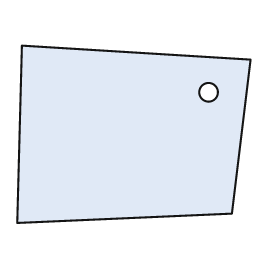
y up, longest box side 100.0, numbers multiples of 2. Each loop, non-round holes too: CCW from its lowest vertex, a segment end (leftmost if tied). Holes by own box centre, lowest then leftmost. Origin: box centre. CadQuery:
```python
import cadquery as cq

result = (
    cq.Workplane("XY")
    .moveTo(-50.0, -38.0)
    .lineTo(42.0, -34.0)
    .lineTo(50.0, 32.0)
    .lineTo(-48.0, 38.0)
    .close()
    .moveTo(32.0, 18.0)
    .circle(4.0)
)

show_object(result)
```